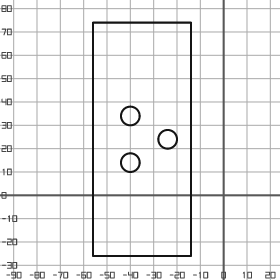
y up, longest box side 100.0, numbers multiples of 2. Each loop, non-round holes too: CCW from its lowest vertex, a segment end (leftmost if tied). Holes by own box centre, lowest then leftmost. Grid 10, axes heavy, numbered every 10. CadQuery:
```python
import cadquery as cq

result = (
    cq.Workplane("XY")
    .moveTo(-56.0, -26.0)
    .lineTo(-14.0, -26.0)
    .lineTo(-14.0, 74.0)
    .lineTo(-56.0, 74.0)
    .close()
    .moveTo(-40.0, 14.0)
    .circle(4.0)
    .moveTo(-24.0, 24.0)
    .circle(4.0)
    .moveTo(-40.0, 34.0)
    .circle(4.0)
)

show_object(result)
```